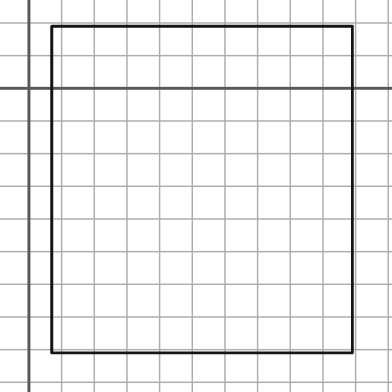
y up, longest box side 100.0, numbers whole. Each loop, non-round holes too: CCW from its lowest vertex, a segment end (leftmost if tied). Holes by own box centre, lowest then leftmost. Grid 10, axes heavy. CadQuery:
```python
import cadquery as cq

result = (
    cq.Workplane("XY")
    .moveTo(7.0, -81.0)
    .lineTo(99.0, -81.0)
    .lineTo(99.0, 19.0)
    .lineTo(7.0, 19.0)
    .close()
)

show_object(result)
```